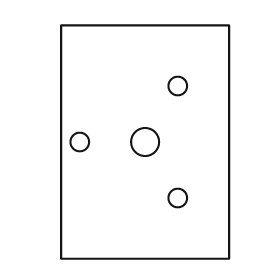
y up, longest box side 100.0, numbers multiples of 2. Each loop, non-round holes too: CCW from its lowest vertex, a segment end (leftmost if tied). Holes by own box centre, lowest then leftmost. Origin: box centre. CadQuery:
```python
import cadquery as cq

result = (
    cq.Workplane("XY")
    .moveTo(-36.0, -50.0)
    .lineTo(36.0, -50.0)
    .lineTo(36.0, 50.0)
    .lineTo(-36.0, 50.0)
    .close()
    .moveTo(14.0, -24.0)
    .circle(4.0)
    .moveTo(-28.0, 0.0)
    .circle(4.0)
    .moveTo(0.0, 0.0)
    .circle(6.0)
    .moveTo(14.0, 24.0)
    .circle(4.0)
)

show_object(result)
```